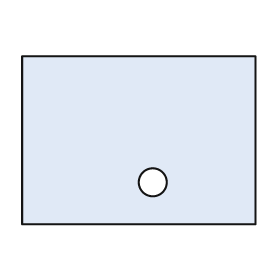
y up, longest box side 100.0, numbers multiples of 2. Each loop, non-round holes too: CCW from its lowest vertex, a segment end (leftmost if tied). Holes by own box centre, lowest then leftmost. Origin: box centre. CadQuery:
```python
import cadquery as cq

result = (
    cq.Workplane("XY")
    .moveTo(-50.0, -36.0)
    .lineTo(50.0, -36.0)
    .lineTo(50.0, 36.0)
    .lineTo(-50.0, 36.0)
    .close()
    .moveTo(6.0, -18.0)
    .circle(6.0)
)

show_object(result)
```